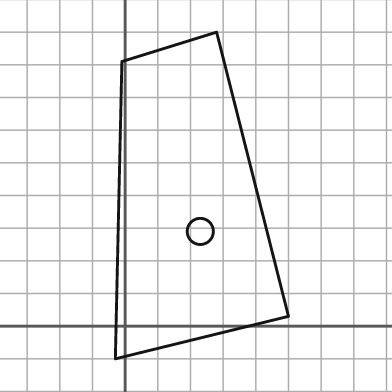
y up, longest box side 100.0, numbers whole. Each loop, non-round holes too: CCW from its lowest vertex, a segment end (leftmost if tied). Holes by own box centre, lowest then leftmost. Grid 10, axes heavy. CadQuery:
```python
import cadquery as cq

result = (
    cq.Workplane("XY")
    .moveTo(-3.0, -10.0)
    .lineTo(50.0, 3.0)
    .lineTo(28.0, 90.0)
    .lineTo(-1.0, 81.0)
    .close()
    .moveTo(23.0, 29.0)
    .circle(4.0)
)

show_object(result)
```